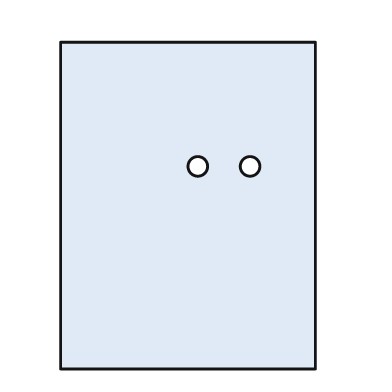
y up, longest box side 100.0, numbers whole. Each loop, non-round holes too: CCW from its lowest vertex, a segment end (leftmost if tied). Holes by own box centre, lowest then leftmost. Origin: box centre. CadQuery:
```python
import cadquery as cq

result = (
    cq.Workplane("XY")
    .moveTo(-39.0, -50.0)
    .lineTo(39.0, -50.0)
    .lineTo(39.0, 50.0)
    .lineTo(-39.0, 50.0)
    .close()
    .moveTo(3.0, 12.0)
    .circle(3.0)
    .moveTo(19.0, 12.0)
    .circle(3.0)
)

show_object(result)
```